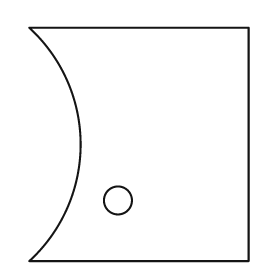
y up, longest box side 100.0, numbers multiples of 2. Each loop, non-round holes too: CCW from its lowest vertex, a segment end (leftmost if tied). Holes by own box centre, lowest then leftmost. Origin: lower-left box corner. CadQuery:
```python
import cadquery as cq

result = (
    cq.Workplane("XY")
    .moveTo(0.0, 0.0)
    .lineTo(94.0, 0.0)
    .lineTo(94.0, 100.0)
    .lineTo(0.0, 100.0)
    .threePointArc((22.0, 50.0), (0.0, 0.0))
    .close()
    .moveTo(38.0, 26.0)
    .circle(6.0)
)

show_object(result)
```